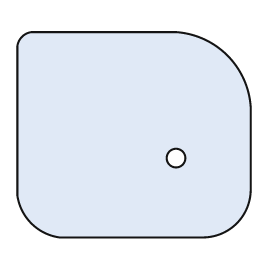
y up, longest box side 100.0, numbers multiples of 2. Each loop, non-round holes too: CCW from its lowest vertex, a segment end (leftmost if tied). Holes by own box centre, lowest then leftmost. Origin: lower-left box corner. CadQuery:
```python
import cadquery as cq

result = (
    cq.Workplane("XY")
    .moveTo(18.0, 0.0)
    .lineTo(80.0, 0.0)
    .threePointArc((94.0, 6.0), (100.0, 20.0))
    .lineTo(100.0, 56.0)
    .threePointArc((90.0, 78.0), (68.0, 88.0))
    .lineTo(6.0, 88.0)
    .threePointArc((2.0, 86.0), (0.0, 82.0))
    .lineTo(0.0, 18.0)
    .threePointArc((6.0, 6.0), (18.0, 0.0))
    .close()
    .moveTo(68.0, 34.0)
    .circle(4.0)
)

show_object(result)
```